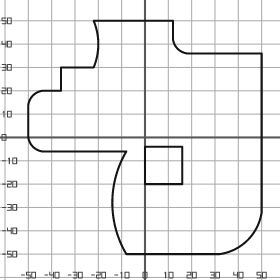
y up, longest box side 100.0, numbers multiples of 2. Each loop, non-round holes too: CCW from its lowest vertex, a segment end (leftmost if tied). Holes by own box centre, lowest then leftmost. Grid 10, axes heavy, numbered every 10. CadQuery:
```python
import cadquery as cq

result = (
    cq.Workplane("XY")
    .moveTo(-8.0, -50.0)
    .lineTo(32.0, -50.0)
    .threePointArc((44.0, -44.0), (50.0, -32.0))
    .lineTo(50.0, 36.0)
    .lineTo(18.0, 36.0)
    .threePointArc((14.0, 38.0), (12.0, 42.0))
    .lineTo(12.0, 50.0)
    .lineTo(-22.0, 50.0)
    .threePointArc((-20.0, 40.0), (-22.0, 30.0))
    .lineTo(-36.0, 30.0)
    .lineTo(-36.0, 20.0)
    .lineTo(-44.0, 20.0)
    .threePointArc((-48.0, 18.0), (-50.0, 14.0))
    .lineTo(-50.0, 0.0)
    .threePointArc((-48.0, -4.0), (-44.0, -6.0))
    .lineTo(-8.0, -6.0)
    .threePointArc((-14.0, -28.0), (-8.0, -50.0))
    .close()
    .moveTo(0.0, -20.0)
    .lineTo(16.0, -20.0)
    .lineTo(16.0, -4.0)
    .lineTo(0.0, -4.0)
    .close()
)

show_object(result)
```